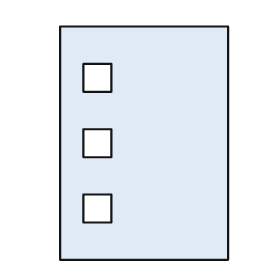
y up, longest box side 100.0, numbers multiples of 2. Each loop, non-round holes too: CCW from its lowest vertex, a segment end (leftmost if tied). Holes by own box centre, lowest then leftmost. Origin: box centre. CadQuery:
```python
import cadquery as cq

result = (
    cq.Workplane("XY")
    .moveTo(-36.0, -50.0)
    .lineTo(36.0, -50.0)
    .lineTo(36.0, 50.0)
    .lineTo(-36.0, 50.0)
    .close()
    .moveTo(-26.0, -34.0)
    .lineTo(-14.0, -34.0)
    .lineTo(-14.0, -22.0)
    .lineTo(-26.0, -22.0)
    .close()
    .moveTo(-26.0, -6.0)
    .lineTo(-14.0, -6.0)
    .lineTo(-14.0, 6.0)
    .lineTo(-26.0, 6.0)
    .close()
    .moveTo(-26.0, 22.0)
    .lineTo(-14.0, 22.0)
    .lineTo(-14.0, 34.0)
    .lineTo(-26.0, 34.0)
    .close()
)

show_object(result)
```